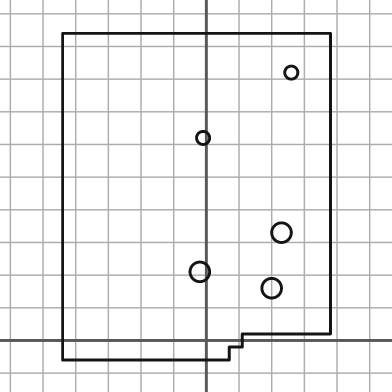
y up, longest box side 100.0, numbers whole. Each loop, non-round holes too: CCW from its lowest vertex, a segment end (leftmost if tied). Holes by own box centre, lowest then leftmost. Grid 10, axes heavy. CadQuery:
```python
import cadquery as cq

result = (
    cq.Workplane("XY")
    .moveTo(-44.0, -6.0)
    .lineTo(7.0, -6.0)
    .lineTo(7.0, -2.0)
    .lineTo(11.0, -2.0)
    .lineTo(11.0, 2.0)
    .lineTo(38.0, 2.0)
    .lineTo(38.0, 94.0)
    .lineTo(-44.0, 94.0)
    .close()
    .moveTo(20.0, 16.0)
    .circle(3.0)
    .moveTo(-2.0, 21.0)
    .circle(3.0)
    .moveTo(23.0, 33.0)
    .circle(3.0)
    .moveTo(-1.0, 62.0)
    .circle(2.0)
    .moveTo(26.0, 82.0)
    .circle(2.0)
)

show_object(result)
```